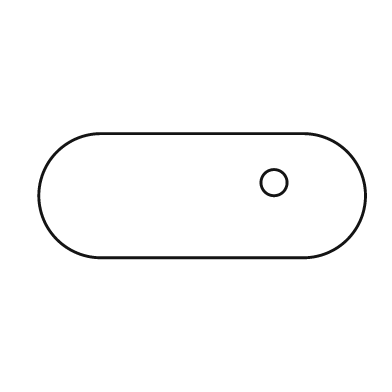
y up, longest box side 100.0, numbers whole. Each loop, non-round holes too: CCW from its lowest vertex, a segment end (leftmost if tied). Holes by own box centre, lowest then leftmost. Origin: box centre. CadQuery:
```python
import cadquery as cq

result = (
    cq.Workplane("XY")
    .moveTo(-31.0, -19.0)
    .lineTo(31.0, -19.0)
    .threePointArc((50.0, 0.0), (31.0, 19.0))
    .lineTo(-31.0, 19.0)
    .threePointArc((-50.0, 0.0), (-31.0, -19.0))
    .close()
    .moveTo(22.0, 4.0)
    .circle(4.0)
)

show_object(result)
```